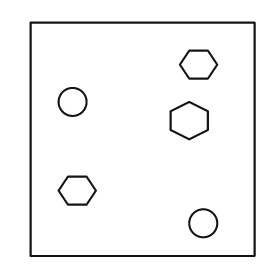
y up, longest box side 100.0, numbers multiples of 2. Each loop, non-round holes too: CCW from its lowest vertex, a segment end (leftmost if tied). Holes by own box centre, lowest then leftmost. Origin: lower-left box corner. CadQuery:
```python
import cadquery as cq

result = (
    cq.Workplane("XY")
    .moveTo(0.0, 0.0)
    .lineTo(96.0, 0.0)
    .lineTo(96.0, 100.0)
    .lineTo(0.0, 100.0)
    .close()
    .moveTo(74.0, 14.0)
    .circle(6.0)
    .moveTo(16.0, 22.0)
    .lineTo(24.0, 22.0)
    .lineTo(28.0, 28.0)
    .lineTo(24.0, 34.0)
    .lineTo(16.0, 34.0)
    .lineTo(12.0, 28.0)
    .close()
    .moveTo(68.0, 50.0)
    .lineTo(76.0, 54.0)
    .lineTo(76.0, 62.0)
    .lineTo(68.0, 66.0)
    .lineTo(60.0, 62.0)
    .lineTo(60.0, 54.0)
    .close()
    .moveTo(18.0, 66.0)
    .circle(6.0)
    .moveTo(68.0, 76.0)
    .lineTo(76.0, 76.0)
    .lineTo(80.0, 82.0)
    .lineTo(76.0, 88.0)
    .lineTo(68.0, 88.0)
    .lineTo(64.0, 82.0)
    .close()
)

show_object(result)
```